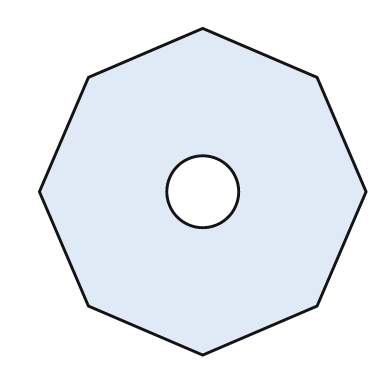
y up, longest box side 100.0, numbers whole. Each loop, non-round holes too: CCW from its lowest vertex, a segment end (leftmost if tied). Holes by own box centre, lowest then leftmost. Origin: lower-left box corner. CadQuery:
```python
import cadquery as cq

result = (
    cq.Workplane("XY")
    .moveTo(50.0, 0.0)
    .lineTo(85.0, 15.0)
    .lineTo(100.0, 50.0)
    .lineTo(85.0, 85.0)
    .lineTo(50.0, 100.0)
    .lineTo(15.0, 85.0)
    .lineTo(0.0, 50.0)
    .lineTo(15.0, 15.0)
    .close()
    .moveTo(50.0, 50.0)
    .circle(11.0)
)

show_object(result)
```